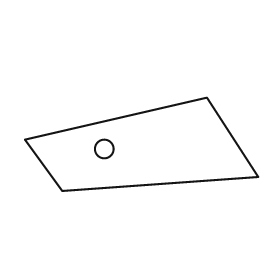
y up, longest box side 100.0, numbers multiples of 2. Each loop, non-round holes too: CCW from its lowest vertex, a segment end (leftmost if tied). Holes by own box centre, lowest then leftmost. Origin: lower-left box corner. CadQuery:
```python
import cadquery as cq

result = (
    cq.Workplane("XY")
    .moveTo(16.0, 0.0)
    .lineTo(100.0, 6.0)
    .lineTo(78.0, 40.0)
    .lineTo(0.0, 22.0)
    .close()
    .moveTo(34.0, 18.0)
    .circle(4.0)
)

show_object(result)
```